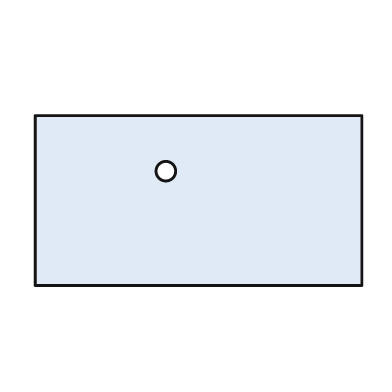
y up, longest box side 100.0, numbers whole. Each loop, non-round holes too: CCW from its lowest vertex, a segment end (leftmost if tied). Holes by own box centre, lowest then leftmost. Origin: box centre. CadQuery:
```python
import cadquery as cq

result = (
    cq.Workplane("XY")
    .moveTo(-50.0, -26.0)
    .lineTo(50.0, -26.0)
    .lineTo(50.0, 26.0)
    .lineTo(-50.0, 26.0)
    .close()
    .moveTo(-10.0, 9.0)
    .circle(3.0)
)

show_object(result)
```